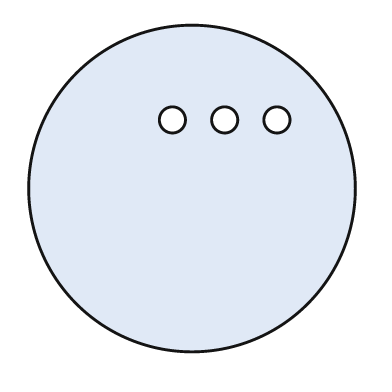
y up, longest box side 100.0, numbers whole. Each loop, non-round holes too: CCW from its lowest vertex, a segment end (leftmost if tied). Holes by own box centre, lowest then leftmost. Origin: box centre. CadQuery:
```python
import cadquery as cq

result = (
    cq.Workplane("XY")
    .moveTo(0.0, 0.0)
    .circle(50.0)
    .moveTo(-6.0, 21.0)
    .circle(4.0)
    .moveTo(10.0, 21.0)
    .circle(4.0)
    .moveTo(26.0, 21.0)
    .circle(4.0)
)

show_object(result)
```